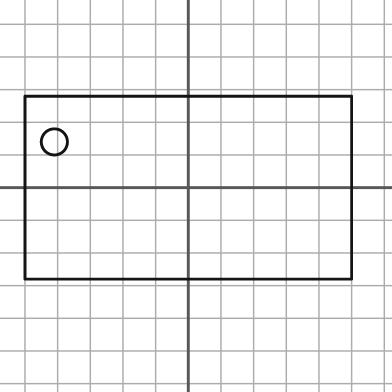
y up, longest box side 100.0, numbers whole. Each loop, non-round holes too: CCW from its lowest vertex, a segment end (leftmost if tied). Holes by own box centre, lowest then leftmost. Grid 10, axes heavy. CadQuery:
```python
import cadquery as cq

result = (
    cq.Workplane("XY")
    .moveTo(-50.0, -28.0)
    .lineTo(50.0, -28.0)
    .lineTo(50.0, 28.0)
    .lineTo(-50.0, 28.0)
    .close()
    .moveTo(-41.0, 14.0)
    .circle(4.0)
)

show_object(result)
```